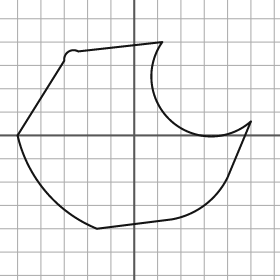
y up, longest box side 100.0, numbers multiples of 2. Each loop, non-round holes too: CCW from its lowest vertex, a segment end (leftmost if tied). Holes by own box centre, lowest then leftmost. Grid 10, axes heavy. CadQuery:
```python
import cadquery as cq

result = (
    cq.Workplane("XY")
    .moveTo(-16.0, -40.0)
    .lineTo(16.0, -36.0)
    .threePointArc((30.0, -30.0), (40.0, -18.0))
    .lineTo(50.0, 6.0)
    .threePointArc((16.0, 6.0), (12.0, 40.0))
    .lineTo(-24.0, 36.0)
    .threePointArc((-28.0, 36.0), (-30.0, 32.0))
    .lineTo(-50.0, 0.0)
    .threePointArc((-38.0, -24.0), (-16.0, -40.0))
    .close()
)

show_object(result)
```